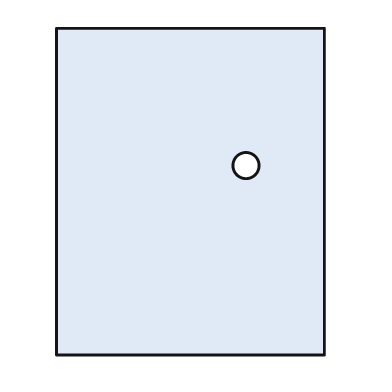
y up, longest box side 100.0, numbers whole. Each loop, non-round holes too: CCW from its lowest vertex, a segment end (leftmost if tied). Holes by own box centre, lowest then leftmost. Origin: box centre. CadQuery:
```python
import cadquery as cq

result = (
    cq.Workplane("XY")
    .moveTo(-41.0, -50.0)
    .lineTo(41.0, -50.0)
    .lineTo(41.0, 50.0)
    .lineTo(-41.0, 50.0)
    .close()
    .moveTo(17.0, 8.0)
    .circle(4.0)
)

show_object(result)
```